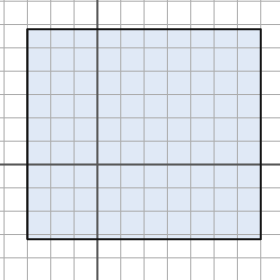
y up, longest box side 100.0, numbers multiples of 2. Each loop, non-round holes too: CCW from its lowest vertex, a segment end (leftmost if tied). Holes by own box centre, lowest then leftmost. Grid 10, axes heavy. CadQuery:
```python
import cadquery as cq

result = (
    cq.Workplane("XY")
    .moveTo(-30.0, -32.0)
    .lineTo(70.0, -32.0)
    .lineTo(70.0, 58.0)
    .lineTo(-30.0, 58.0)
    .close()
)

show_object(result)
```